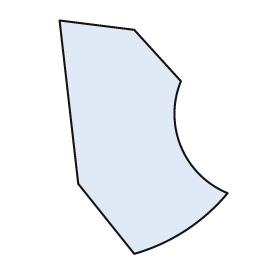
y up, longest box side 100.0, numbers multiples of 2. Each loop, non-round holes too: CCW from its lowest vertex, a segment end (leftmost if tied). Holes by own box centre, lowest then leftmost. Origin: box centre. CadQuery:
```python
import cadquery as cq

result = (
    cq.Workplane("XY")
    .moveTo(-4.0, -50.0)
    .threePointArc((18.0, -40.0), (36.0, -24.0))
    .threePointArc((16.0, -4.0), (16.0, 24.0))
    .lineTo(-4.0, 46.0)
    .lineTo(-36.0, 50.0)
    .lineTo(-28.0, -20.0)
    .close()
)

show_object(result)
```